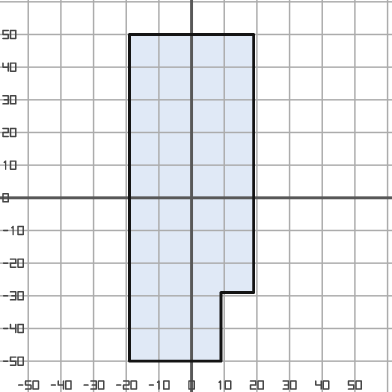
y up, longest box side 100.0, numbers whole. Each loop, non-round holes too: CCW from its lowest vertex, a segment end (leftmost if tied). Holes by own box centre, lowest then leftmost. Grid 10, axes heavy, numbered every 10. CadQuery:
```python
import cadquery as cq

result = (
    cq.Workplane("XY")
    .moveTo(-19.0, -50.0)
    .lineTo(9.0, -50.0)
    .lineTo(9.0, -29.0)
    .lineTo(19.0, -29.0)
    .lineTo(19.0, 50.0)
    .lineTo(-19.0, 50.0)
    .close()
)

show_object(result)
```